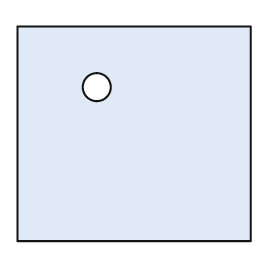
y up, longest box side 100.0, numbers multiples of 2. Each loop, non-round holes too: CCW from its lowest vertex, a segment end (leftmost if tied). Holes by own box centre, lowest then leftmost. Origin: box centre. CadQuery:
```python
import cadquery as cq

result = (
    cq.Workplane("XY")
    .moveTo(-50.0, -46.0)
    .lineTo(50.0, -46.0)
    .lineTo(50.0, 46.0)
    .lineTo(-50.0, 46.0)
    .close()
    .moveTo(-16.0, 20.0)
    .circle(6.0)
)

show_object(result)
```